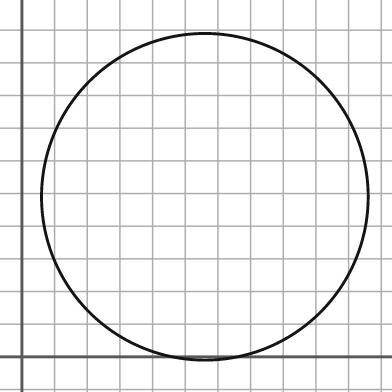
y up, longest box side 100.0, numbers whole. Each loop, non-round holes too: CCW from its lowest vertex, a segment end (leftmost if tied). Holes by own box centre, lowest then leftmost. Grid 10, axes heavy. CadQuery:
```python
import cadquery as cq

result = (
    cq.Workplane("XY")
    .moveTo(56.0, 49.0)
    .circle(50.0)
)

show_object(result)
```